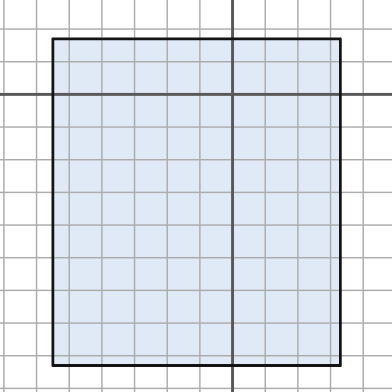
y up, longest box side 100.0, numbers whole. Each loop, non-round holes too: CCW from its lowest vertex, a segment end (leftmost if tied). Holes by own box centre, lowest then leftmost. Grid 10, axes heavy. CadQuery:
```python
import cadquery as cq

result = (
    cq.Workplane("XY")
    .moveTo(-55.0, -83.0)
    .lineTo(33.0, -83.0)
    .lineTo(33.0, 17.0)
    .lineTo(-55.0, 17.0)
    .close()
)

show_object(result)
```